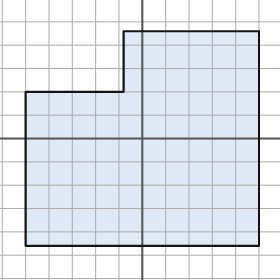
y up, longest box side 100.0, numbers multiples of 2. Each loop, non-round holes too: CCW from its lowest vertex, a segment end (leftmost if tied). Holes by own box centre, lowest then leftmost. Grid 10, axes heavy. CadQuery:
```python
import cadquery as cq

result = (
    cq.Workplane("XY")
    .moveTo(-50.0, -46.0)
    .lineTo(50.0, -46.0)
    .lineTo(50.0, 46.0)
    .lineTo(-8.0, 46.0)
    .lineTo(-8.0, 20.0)
    .lineTo(-50.0, 20.0)
    .close()
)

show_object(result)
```